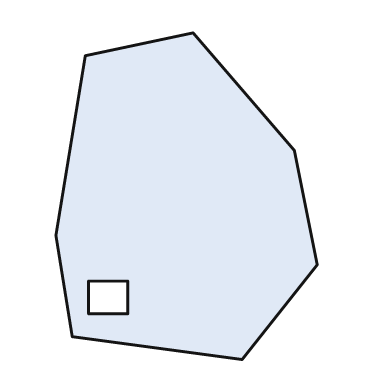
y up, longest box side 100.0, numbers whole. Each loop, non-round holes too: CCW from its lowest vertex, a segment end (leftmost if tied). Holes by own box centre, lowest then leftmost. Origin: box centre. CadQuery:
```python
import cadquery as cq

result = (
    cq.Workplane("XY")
    .moveTo(17.0, -50.0)
    .lineTo(40.0, -21.0)
    .lineTo(33.0, 14.0)
    .lineTo(2.0, 50.0)
    .lineTo(-31.0, 43.0)
    .lineTo(-40.0, -12.0)
    .lineTo(-35.0, -43.0)
    .close()
    .moveTo(-30.0, -36.0)
    .lineTo(-18.0, -36.0)
    .lineTo(-18.0, -26.0)
    .lineTo(-30.0, -26.0)
    .close()
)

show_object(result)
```